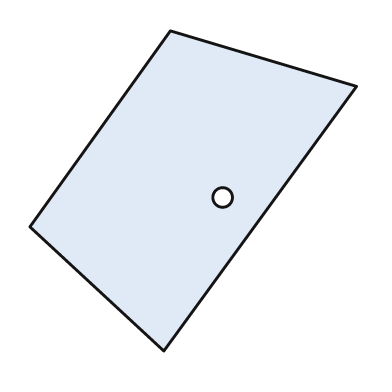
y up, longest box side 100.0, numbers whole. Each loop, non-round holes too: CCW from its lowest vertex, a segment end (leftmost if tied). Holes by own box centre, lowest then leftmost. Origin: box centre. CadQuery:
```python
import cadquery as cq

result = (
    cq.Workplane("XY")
    .moveTo(-9.0, -49.0)
    .lineTo(50.0, 32.0)
    .lineTo(-7.0, 49.0)
    .lineTo(-50.0, -11.0)
    .close()
    .moveTo(9.0, -2.0)
    .circle(3.0)
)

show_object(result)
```